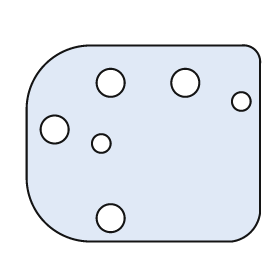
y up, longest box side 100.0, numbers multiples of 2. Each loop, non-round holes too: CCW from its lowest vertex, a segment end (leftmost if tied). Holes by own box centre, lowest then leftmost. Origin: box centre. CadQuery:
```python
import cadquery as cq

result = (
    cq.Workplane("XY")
    .moveTo(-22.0, -42.0)
    .lineTo(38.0, -42.0)
    .threePointArc((46.0, -38.0), (50.0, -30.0))
    .lineTo(50.0, 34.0)
    .threePointArc((48.0, 40.0), (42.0, 42.0))
    .lineTo(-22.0, 42.0)
    .threePointArc((-42.0, 34.0), (-50.0, 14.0))
    .lineTo(-50.0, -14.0)
    .threePointArc((-42.0, -34.0), (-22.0, -42.0))
    .close()
    .moveTo(-14.0, -32.0)
    .circle(6.0)
    .moveTo(-18.0, 0.0)
    .circle(4.0)
    .moveTo(-38.0, 6.0)
    .circle(6.0)
    .moveTo(42.0, 18.0)
    .circle(4.0)
    .moveTo(-14.0, 26.0)
    .circle(6.0)
    .moveTo(18.0, 26.0)
    .circle(6.0)
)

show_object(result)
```